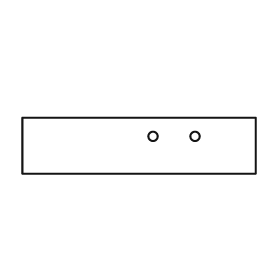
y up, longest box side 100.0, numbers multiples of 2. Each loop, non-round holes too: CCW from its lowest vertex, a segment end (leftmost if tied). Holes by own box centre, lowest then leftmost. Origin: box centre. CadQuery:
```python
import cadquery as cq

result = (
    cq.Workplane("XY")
    .moveTo(-50.0, -12.0)
    .lineTo(50.0, -12.0)
    .lineTo(50.0, 12.0)
    .lineTo(-50.0, 12.0)
    .close()
    .moveTo(6.0, 4.0)
    .circle(2.0)
    .moveTo(24.0, 4.0)
    .circle(2.0)
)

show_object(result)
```